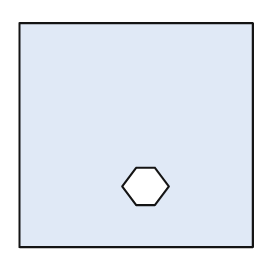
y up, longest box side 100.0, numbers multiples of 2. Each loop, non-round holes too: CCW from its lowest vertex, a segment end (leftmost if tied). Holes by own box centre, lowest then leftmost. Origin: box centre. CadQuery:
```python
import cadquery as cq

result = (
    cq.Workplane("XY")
    .moveTo(-50.0, -48.0)
    .lineTo(50.0, -48.0)
    .lineTo(50.0, 48.0)
    .lineTo(-50.0, 48.0)
    .close()
    .moveTo(0.0, -30.0)
    .lineTo(8.0, -30.0)
    .lineTo(14.0, -22.0)
    .lineTo(8.0, -14.0)
    .lineTo(0.0, -14.0)
    .lineTo(-6.0, -22.0)
    .close()
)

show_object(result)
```